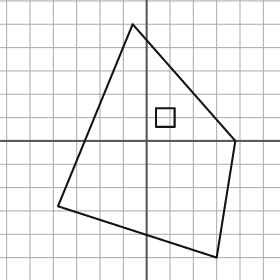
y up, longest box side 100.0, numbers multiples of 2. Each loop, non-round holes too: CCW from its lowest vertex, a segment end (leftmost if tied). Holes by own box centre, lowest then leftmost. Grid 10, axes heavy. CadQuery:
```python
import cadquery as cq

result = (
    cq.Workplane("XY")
    .moveTo(30.0, -50.0)
    .lineTo(38.0, 0.0)
    .lineTo(-6.0, 50.0)
    .lineTo(-38.0, -28.0)
    .close()
    .moveTo(4.0, 6.0)
    .lineTo(12.0, 6.0)
    .lineTo(12.0, 14.0)
    .lineTo(4.0, 14.0)
    .close()
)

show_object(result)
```